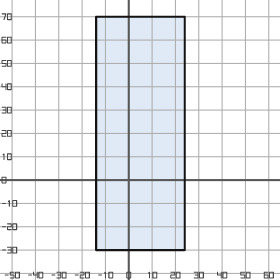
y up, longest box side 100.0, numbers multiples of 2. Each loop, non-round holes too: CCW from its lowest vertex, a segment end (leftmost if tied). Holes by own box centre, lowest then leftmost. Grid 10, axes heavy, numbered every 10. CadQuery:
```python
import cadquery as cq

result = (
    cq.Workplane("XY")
    .moveTo(-14.0, -30.0)
    .lineTo(24.0, -30.0)
    .lineTo(24.0, 70.0)
    .lineTo(-14.0, 70.0)
    .close()
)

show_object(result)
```